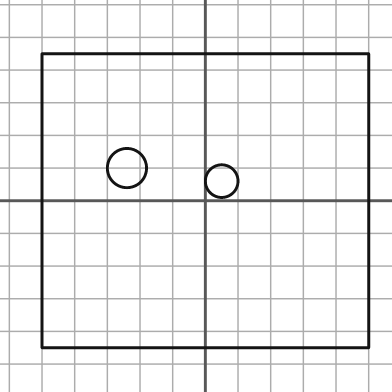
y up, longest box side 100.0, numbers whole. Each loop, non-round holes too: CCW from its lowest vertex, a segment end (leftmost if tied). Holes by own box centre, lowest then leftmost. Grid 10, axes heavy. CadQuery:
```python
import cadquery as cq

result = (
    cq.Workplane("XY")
    .moveTo(-50.0, -45.0)
    .lineTo(50.0, -45.0)
    .lineTo(50.0, 45.0)
    .lineTo(-50.0, 45.0)
    .close()
    .moveTo(5.0, 6.0)
    .circle(5.0)
    .moveTo(-24.0, 10.0)
    .circle(6.0)
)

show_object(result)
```